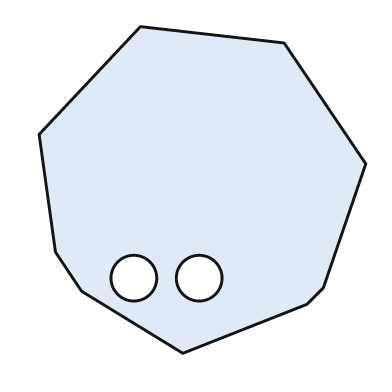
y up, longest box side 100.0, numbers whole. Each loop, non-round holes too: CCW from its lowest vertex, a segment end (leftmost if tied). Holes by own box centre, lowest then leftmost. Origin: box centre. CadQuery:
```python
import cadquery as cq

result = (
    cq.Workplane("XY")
    .moveTo(-6.0, -50.0)
    .lineTo(32.0, -35.0)
    .lineTo(37.0, -30.0)
    .lineTo(50.0, 8.0)
    .lineTo(25.0, 45.0)
    .lineTo(-19.0, 50.0)
    .lineTo(-50.0, 17.0)
    .lineTo(-45.0, -19.0)
    .lineTo(-37.0, -31.0)
    .close()
    .moveTo(-21.0, -27.0)
    .circle(7.0)
    .moveTo(-1.0, -27.0)
    .circle(7.0)
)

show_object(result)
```